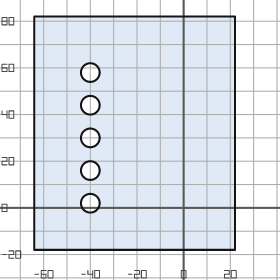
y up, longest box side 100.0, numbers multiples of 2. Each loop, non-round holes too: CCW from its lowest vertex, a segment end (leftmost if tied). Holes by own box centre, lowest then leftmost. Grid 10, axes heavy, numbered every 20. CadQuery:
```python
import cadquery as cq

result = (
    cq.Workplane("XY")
    .moveTo(-64.0, -18.0)
    .lineTo(22.0, -18.0)
    .lineTo(22.0, 82.0)
    .lineTo(-64.0, 82.0)
    .close()
    .moveTo(-40.0, 2.0)
    .circle(4.0)
    .moveTo(-40.0, 16.0)
    .circle(4.0)
    .moveTo(-40.0, 30.0)
    .circle(4.0)
    .moveTo(-40.0, 44.0)
    .circle(4.0)
    .moveTo(-40.0, 58.0)
    .circle(4.0)
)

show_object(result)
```